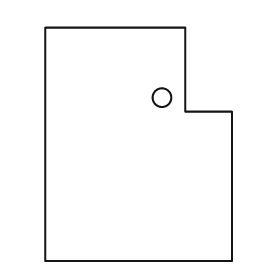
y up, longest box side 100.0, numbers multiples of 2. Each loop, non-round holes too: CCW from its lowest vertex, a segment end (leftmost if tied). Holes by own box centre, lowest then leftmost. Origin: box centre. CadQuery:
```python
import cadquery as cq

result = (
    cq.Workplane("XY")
    .moveTo(-40.0, -50.0)
    .lineTo(40.0, -50.0)
    .lineTo(40.0, 14.0)
    .lineTo(20.0, 14.0)
    .lineTo(20.0, 50.0)
    .lineTo(-40.0, 50.0)
    .close()
    .moveTo(10.0, 20.0)
    .circle(4.0)
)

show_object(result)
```